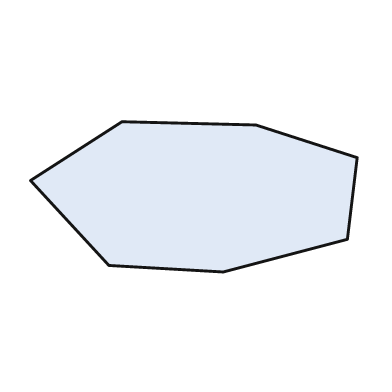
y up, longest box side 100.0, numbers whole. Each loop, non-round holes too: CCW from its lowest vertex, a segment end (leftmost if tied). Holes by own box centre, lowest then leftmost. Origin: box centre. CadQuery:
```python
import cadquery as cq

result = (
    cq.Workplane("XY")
    .moveTo(9.0, -23.0)
    .lineTo(47.0, -13.0)
    .lineTo(50.0, 12.0)
    .lineTo(19.0, 22.0)
    .lineTo(-22.0, 23.0)
    .lineTo(-50.0, 5.0)
    .lineTo(-26.0, -21.0)
    .close()
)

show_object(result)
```